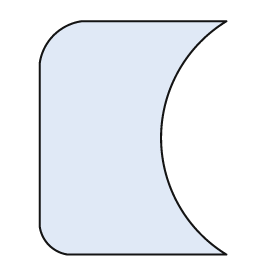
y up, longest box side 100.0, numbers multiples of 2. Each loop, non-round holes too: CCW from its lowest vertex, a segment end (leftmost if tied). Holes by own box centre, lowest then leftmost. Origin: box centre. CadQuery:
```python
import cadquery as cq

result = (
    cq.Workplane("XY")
    .moveTo(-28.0, -50.0)
    .lineTo(40.0, -50.0)
    .threePointArc((12.0, 0.0), (40.0, 50.0))
    .lineTo(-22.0, 50.0)
    .threePointArc((-34.0, 44.0), (-40.0, 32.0))
    .lineTo(-40.0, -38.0)
    .threePointArc((-36.0, -46.0), (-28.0, -50.0))
    .close()
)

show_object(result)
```